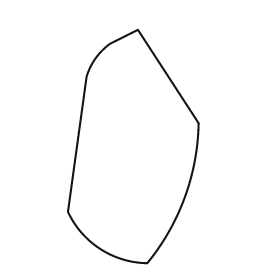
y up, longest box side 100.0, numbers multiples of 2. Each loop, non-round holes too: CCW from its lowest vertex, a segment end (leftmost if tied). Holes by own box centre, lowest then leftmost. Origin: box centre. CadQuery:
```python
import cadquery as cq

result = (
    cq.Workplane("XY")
    .moveTo(6.0, -50.0)
    .threePointArc((22.0, -22.0), (28.0, 10.0))
    .lineTo(2.0, 50.0)
    .lineTo(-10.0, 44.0)
    .threePointArc((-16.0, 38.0), (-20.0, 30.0))
    .lineTo(-28.0, -28.0)
    .threePointArc((-14.0, -44.0), (6.0, -50.0))
    .close()
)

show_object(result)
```